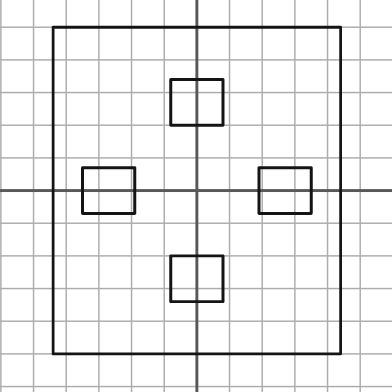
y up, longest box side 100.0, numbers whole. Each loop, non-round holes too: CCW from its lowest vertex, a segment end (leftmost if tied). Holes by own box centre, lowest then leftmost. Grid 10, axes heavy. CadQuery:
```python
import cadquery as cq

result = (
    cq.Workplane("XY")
    .moveTo(-44.0, -50.0)
    .lineTo(44.0, -50.0)
    .lineTo(44.0, 50.0)
    .lineTo(-44.0, 50.0)
    .close()
    .moveTo(-8.0, -34.0)
    .lineTo(8.0, -34.0)
    .lineTo(8.0, -20.0)
    .lineTo(-8.0, -20.0)
    .close()
    .moveTo(-35.0, -7.0)
    .lineTo(-19.0, -7.0)
    .lineTo(-19.0, 7.0)
    .lineTo(-35.0, 7.0)
    .close()
    .moveTo(19.0, -7.0)
    .lineTo(35.0, -7.0)
    .lineTo(35.0, 7.0)
    .lineTo(19.0, 7.0)
    .close()
    .moveTo(-8.0, 20.0)
    .lineTo(8.0, 20.0)
    .lineTo(8.0, 34.0)
    .lineTo(-8.0, 34.0)
    .close()
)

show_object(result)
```